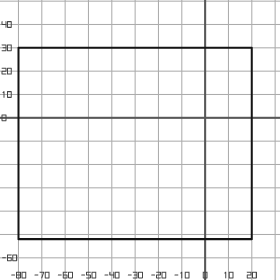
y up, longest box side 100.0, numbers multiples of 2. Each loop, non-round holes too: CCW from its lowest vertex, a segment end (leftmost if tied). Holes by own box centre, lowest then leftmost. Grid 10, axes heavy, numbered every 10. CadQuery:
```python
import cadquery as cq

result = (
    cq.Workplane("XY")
    .moveTo(-80.0, -52.0)
    .lineTo(20.0, -52.0)
    .lineTo(20.0, 30.0)
    .lineTo(-80.0, 30.0)
    .close()
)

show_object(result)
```